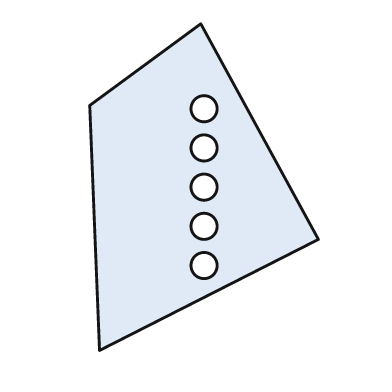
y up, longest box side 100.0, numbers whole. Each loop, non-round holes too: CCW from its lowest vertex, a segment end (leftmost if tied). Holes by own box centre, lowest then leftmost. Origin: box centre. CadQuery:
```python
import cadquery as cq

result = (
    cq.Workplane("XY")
    .moveTo(-32.0, -50.0)
    .lineTo(35.0, -16.0)
    .lineTo(-1.0, 50.0)
    .lineTo(-35.0, 25.0)
    .close()
    .moveTo(0.0, -24.0)
    .circle(4.0)
    .moveTo(0.0, -12.0)
    .circle(4.0)
    .moveTo(0.0, 0.0)
    .circle(4.0)
    .moveTo(0.0, 12.0)
    .circle(4.0)
    .moveTo(0.0, 24.0)
    .circle(4.0)
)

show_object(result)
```